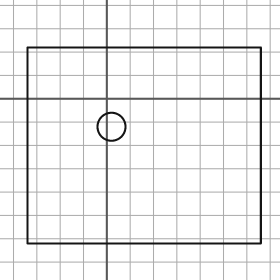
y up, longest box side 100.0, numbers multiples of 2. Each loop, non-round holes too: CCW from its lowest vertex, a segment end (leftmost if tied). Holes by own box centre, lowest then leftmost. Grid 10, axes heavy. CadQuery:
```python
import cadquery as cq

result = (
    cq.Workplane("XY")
    .moveTo(-34.0, -62.0)
    .lineTo(66.0, -62.0)
    .lineTo(66.0, 22.0)
    .lineTo(-34.0, 22.0)
    .close()
    .moveTo(2.0, -12.0)
    .circle(6.0)
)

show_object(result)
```